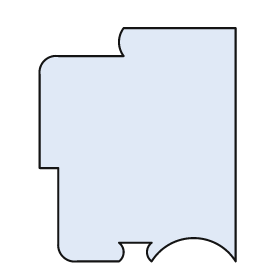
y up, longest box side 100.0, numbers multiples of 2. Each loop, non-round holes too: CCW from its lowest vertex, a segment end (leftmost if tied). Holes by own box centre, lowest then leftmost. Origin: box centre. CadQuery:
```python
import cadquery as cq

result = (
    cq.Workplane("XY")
    .moveTo(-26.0, -50.0)
    .lineTo(-8.0, -50.0)
    .threePointArc((-6.0, -46.0), (-8.0, -42.0))
    .lineTo(6.0, -42.0)
    .threePointArc((4.0, -46.0), (6.0, -50.0))
    .threePointArc((24.0, -40.0), (42.0, -50.0))
    .lineTo(42.0, 50.0)
    .lineTo(-6.0, 50.0)
    .threePointArc((-8.0, 44.0), (-6.0, 38.0))
    .lineTo(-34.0, 38.0)
    .threePointArc((-40.0, 36.0), (-42.0, 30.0))
    .lineTo(-42.0, -10.0)
    .lineTo(-34.0, -10.0)
    .lineTo(-34.0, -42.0)
    .threePointArc((-32.0, -48.0), (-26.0, -50.0))
    .close()
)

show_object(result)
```